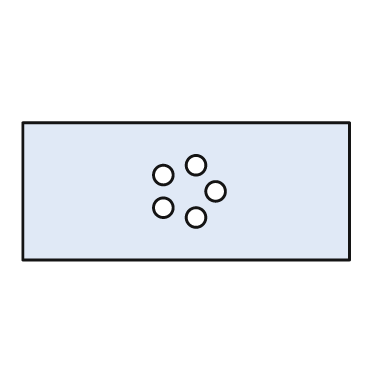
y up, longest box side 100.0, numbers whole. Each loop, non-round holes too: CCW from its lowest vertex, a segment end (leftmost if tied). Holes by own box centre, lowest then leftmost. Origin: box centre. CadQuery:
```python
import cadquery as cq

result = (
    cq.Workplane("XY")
    .moveTo(-50.0, -21.0)
    .lineTo(50.0, -21.0)
    .lineTo(50.0, 21.0)
    .lineTo(-50.0, 21.0)
    .close()
    .moveTo(3.0, -8.0)
    .circle(3.0)
    .moveTo(-7.0, -5.0)
    .circle(3.0)
    .moveTo(9.0, 0.0)
    .circle(3.0)
    .moveTo(-7.0, 5.0)
    .circle(3.0)
    .moveTo(3.0, 8.0)
    .circle(3.0)
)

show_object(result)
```